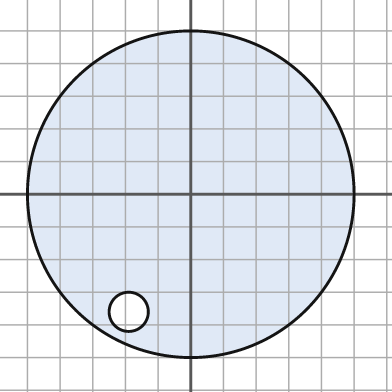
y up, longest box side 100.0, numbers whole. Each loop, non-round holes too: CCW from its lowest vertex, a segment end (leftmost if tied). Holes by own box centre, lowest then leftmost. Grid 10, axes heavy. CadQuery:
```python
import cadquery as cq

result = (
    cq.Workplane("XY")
    .moveTo(0.0, 0.0)
    .circle(50.0)
    .moveTo(-19.0, -36.0)
    .circle(6.0)
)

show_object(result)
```